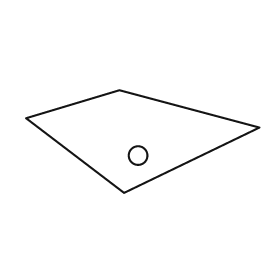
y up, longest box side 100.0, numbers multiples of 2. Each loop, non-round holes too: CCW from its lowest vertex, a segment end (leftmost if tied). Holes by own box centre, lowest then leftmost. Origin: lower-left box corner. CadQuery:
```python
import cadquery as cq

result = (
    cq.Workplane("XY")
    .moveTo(42.0, 0.0)
    .lineTo(100.0, 28.0)
    .lineTo(40.0, 44.0)
    .lineTo(0.0, 32.0)
    .close()
    .moveTo(48.0, 16.0)
    .circle(4.0)
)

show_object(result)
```